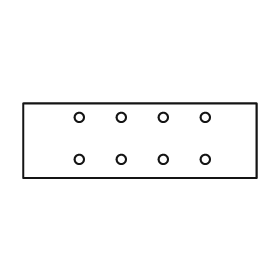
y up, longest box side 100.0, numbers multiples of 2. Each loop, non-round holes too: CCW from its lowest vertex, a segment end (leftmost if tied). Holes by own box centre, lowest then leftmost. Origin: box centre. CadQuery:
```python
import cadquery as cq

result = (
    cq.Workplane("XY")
    .moveTo(-50.0, -16.0)
    .lineTo(50.0, -16.0)
    .lineTo(50.0, 16.0)
    .lineTo(-50.0, 16.0)
    .close()
    .moveTo(-26.0, -8.0)
    .circle(2.0)
    .moveTo(-8.0, -8.0)
    .circle(2.0)
    .moveTo(10.0, -8.0)
    .circle(2.0)
    .moveTo(28.0, -8.0)
    .circle(2.0)
    .moveTo(-26.0, 10.0)
    .circle(2.0)
    .moveTo(-8.0, 10.0)
    .circle(2.0)
    .moveTo(10.0, 10.0)
    .circle(2.0)
    .moveTo(28.0, 10.0)
    .circle(2.0)
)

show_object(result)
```